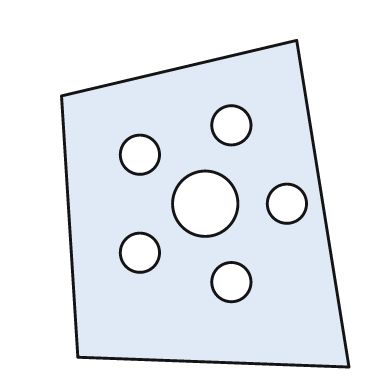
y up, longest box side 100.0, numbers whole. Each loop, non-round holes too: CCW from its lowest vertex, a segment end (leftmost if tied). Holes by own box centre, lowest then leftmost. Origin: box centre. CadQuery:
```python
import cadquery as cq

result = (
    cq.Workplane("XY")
    .moveTo(44.0, -50.0)
    .lineTo(28.0, 50.0)
    .lineTo(-44.0, 33.0)
    .lineTo(-39.0, -47.0)
    .close()
    .moveTo(8.0, -24.0)
    .circle(6.0)
    .moveTo(-20.0, -15.0)
    .circle(6.0)
    .moveTo(0.0, 0.0)
    .circle(10.0)
    .moveTo(25.0, 0.0)
    .circle(6.0)
    .moveTo(-20.0, 15.0)
    .circle(6.0)
    .moveTo(8.0, 24.0)
    .circle(6.0)
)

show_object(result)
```